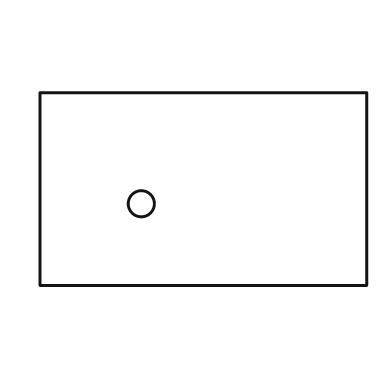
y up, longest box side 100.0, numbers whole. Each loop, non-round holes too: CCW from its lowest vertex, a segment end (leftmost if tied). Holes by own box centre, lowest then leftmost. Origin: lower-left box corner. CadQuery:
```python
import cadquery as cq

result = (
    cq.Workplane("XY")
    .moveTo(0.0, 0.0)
    .lineTo(100.0, 0.0)
    .lineTo(100.0, 59.0)
    .lineTo(0.0, 59.0)
    .close()
    .moveTo(31.0, 25.0)
    .circle(4.0)
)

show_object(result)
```